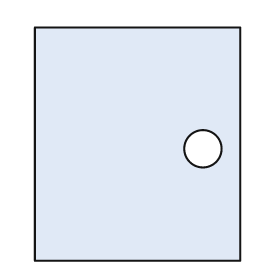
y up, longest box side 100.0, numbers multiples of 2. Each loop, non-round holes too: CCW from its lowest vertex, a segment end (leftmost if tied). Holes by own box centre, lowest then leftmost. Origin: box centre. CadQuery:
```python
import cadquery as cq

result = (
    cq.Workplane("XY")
    .moveTo(-44.0, -50.0)
    .lineTo(44.0, -50.0)
    .lineTo(44.0, 50.0)
    .lineTo(-44.0, 50.0)
    .close()
    .moveTo(28.0, -2.0)
    .circle(8.0)
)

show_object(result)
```